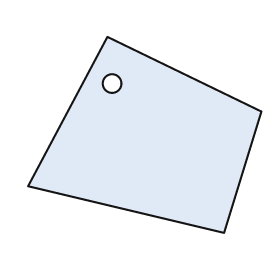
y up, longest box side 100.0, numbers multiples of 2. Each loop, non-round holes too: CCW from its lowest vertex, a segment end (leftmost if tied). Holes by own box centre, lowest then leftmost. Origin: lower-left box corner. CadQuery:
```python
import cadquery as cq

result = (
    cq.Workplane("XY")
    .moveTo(84.0, 0.0)
    .lineTo(100.0, 52.0)
    .lineTo(34.0, 84.0)
    .lineTo(0.0, 20.0)
    .close()
    .moveTo(36.0, 64.0)
    .circle(4.0)
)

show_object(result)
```